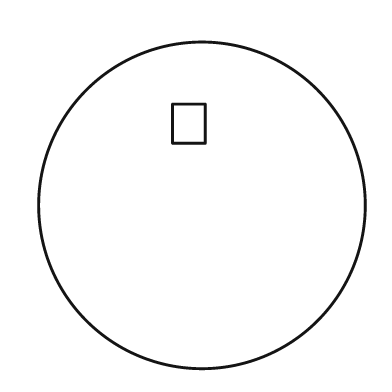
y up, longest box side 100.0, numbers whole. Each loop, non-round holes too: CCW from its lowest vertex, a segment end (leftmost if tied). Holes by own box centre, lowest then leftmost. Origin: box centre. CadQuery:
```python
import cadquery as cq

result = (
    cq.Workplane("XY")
    .moveTo(0.0, 0.0)
    .circle(50.0)
    .moveTo(-9.0, 19.0)
    .lineTo(1.0, 19.0)
    .lineTo(1.0, 31.0)
    .lineTo(-9.0, 31.0)
    .close()
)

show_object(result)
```